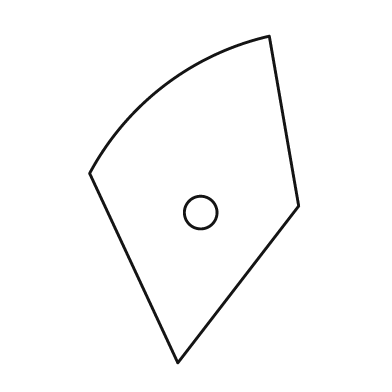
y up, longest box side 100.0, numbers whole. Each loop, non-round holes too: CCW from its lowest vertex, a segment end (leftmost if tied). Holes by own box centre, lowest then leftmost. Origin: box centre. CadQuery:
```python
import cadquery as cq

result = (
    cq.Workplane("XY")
    .moveTo(-5.0, -50.0)
    .lineTo(32.0, -2.0)
    .lineTo(23.0, 50.0)
    .threePointArc((-9.0, 35.0), (-32.0, 8.0))
    .close()
    .moveTo(2.0, -4.0)
    .circle(5.0)
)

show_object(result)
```